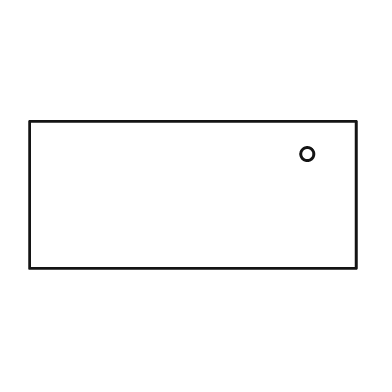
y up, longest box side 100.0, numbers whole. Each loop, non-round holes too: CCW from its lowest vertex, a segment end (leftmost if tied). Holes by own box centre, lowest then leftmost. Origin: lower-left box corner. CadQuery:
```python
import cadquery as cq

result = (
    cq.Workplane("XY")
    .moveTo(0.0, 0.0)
    .lineTo(100.0, 0.0)
    .lineTo(100.0, 45.0)
    .lineTo(0.0, 45.0)
    .close()
    .moveTo(85.0, 35.0)
    .circle(2.0)
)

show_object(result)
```